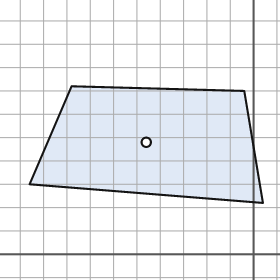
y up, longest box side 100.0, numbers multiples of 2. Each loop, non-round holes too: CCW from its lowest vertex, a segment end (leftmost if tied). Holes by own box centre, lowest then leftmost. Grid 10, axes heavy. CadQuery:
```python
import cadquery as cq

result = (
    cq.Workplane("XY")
    .moveTo(4.0, 22.0)
    .lineTo(-4.0, 70.0)
    .lineTo(-78.0, 72.0)
    .lineTo(-96.0, 30.0)
    .close()
    .moveTo(-46.0, 48.0)
    .circle(2.0)
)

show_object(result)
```